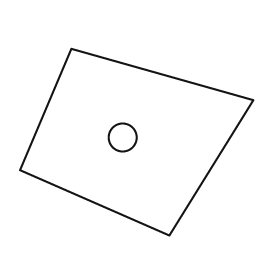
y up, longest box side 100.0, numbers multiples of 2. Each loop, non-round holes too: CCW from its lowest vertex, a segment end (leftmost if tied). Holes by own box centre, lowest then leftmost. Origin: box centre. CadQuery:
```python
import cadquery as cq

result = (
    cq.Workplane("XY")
    .moveTo(14.0, -40.0)
    .lineTo(50.0, 18.0)
    .lineTo(-28.0, 40.0)
    .lineTo(-50.0, -12.0)
    .close()
    .moveTo(-6.0, 2.0)
    .circle(6.0)
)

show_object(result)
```